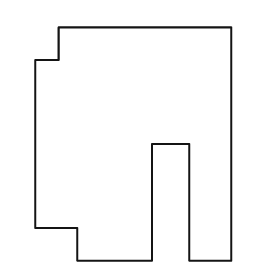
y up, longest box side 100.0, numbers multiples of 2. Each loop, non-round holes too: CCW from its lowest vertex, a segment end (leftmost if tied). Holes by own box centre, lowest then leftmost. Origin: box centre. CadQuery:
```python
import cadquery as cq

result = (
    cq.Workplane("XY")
    .moveTo(-24.0, -50.0)
    .lineTo(8.0, -50.0)
    .lineTo(8.0, 0.0)
    .lineTo(24.0, 0.0)
    .lineTo(24.0, -50.0)
    .lineTo(42.0, -50.0)
    .lineTo(42.0, 50.0)
    .lineTo(-32.0, 50.0)
    .lineTo(-32.0, 36.0)
    .lineTo(-42.0, 36.0)
    .lineTo(-42.0, -36.0)
    .lineTo(-24.0, -36.0)
    .close()
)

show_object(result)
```